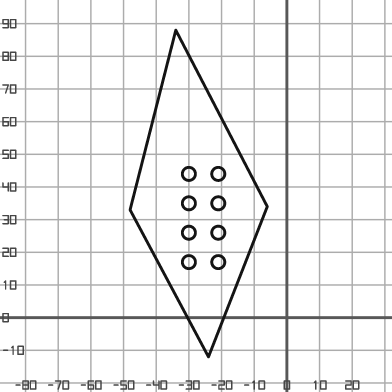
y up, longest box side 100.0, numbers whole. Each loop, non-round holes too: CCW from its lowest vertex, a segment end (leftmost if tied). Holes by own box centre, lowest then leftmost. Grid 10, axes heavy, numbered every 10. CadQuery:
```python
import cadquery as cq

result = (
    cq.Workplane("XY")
    .moveTo(-24.0, -12.0)
    .lineTo(-6.0, 34.0)
    .lineTo(-34.0, 88.0)
    .lineTo(-48.0, 33.0)
    .close()
    .moveTo(-30.0, 17.0)
    .circle(2.0)
    .moveTo(-21.0, 17.0)
    .circle(2.0)
    .moveTo(-30.0, 26.0)
    .circle(2.0)
    .moveTo(-21.0, 26.0)
    .circle(2.0)
    .moveTo(-30.0, 35.0)
    .circle(2.0)
    .moveTo(-21.0, 35.0)
    .circle(2.0)
    .moveTo(-30.0, 44.0)
    .circle(2.0)
    .moveTo(-21.0, 44.0)
    .circle(2.0)
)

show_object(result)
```